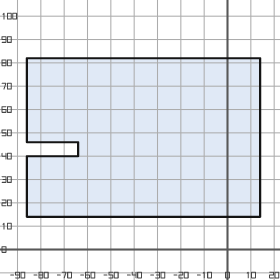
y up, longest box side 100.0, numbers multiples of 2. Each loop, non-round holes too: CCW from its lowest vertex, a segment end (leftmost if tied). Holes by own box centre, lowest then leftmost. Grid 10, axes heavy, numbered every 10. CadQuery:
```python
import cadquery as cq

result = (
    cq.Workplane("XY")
    .moveTo(-86.0, 14.0)
    .lineTo(14.0, 14.0)
    .lineTo(14.0, 82.0)
    .lineTo(-86.0, 82.0)
    .lineTo(-86.0, 46.0)
    .lineTo(-64.0, 46.0)
    .lineTo(-64.0, 40.0)
    .lineTo(-86.0, 40.0)
    .close()
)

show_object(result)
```